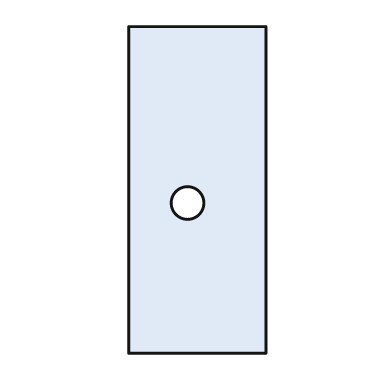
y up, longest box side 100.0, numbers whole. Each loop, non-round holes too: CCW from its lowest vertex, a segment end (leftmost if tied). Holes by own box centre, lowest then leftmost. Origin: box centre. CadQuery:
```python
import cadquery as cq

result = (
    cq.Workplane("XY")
    .moveTo(-21.0, -50.0)
    .lineTo(21.0, -50.0)
    .lineTo(21.0, 50.0)
    .lineTo(-21.0, 50.0)
    .close()
    .moveTo(-3.0, -4.0)
    .circle(5.0)
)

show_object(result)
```